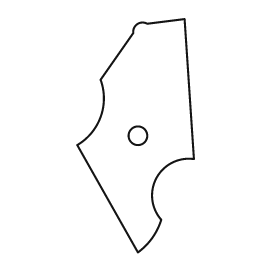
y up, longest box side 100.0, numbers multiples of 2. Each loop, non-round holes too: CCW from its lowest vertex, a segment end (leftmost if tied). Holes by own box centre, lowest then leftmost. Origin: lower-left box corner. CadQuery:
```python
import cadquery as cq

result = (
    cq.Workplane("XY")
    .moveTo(26.0, 0.0)
    .threePointArc((32.0, 6.0), (36.0, 14.0))
    .threePointArc((34.0, 32.0), (50.0, 40.0))
    .lineTo(46.0, 100.0)
    .lineTo(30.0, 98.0)
    .threePointArc((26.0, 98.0), (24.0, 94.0))
    .lineTo(10.0, 74.0)
    .threePointArc((10.0, 58.0), (0.0, 46.0))
    .close()
    .moveTo(26.0, 50.0)
    .circle(4.0)
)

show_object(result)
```